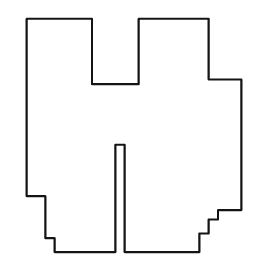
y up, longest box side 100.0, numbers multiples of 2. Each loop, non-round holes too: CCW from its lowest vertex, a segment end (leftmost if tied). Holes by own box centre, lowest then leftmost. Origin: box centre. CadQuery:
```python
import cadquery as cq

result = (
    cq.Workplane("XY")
    .moveTo(-34.0, -50.0)
    .lineTo(-8.0, -50.0)
    .lineTo(-8.0, -4.0)
    .lineTo(-4.0, -4.0)
    .lineTo(-4.0, -50.0)
    .lineTo(28.0, -50.0)
    .lineTo(28.0, -42.0)
    .lineTo(32.0, -42.0)
    .lineTo(32.0, -36.0)
    .lineTo(36.0, -36.0)
    .lineTo(36.0, -32.0)
    .lineTo(46.0, -32.0)
    .lineTo(46.0, 24.0)
    .lineTo(32.0, 24.0)
    .lineTo(32.0, 50.0)
    .lineTo(2.0, 50.0)
    .lineTo(2.0, 22.0)
    .lineTo(-18.0, 22.0)
    .lineTo(-18.0, 50.0)
    .lineTo(-46.0, 50.0)
    .lineTo(-46.0, -26.0)
    .lineTo(-38.0, -26.0)
    .lineTo(-38.0, -44.0)
    .lineTo(-34.0, -44.0)
    .close()
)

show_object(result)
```